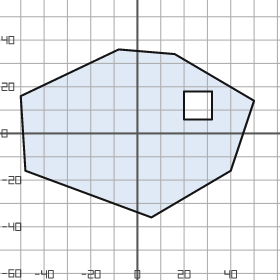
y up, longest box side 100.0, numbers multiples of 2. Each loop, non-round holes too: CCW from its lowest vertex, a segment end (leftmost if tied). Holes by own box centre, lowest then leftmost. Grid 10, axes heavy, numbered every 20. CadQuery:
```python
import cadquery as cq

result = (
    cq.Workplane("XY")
    .moveTo(6.0, -36.0)
    .lineTo(40.0, -16.0)
    .lineTo(50.0, 14.0)
    .lineTo(16.0, 34.0)
    .lineTo(-8.0, 36.0)
    .lineTo(-50.0, 16.0)
    .lineTo(-48.0, -16.0)
    .close()
    .moveTo(20.0, 6.0)
    .lineTo(32.0, 6.0)
    .lineTo(32.0, 18.0)
    .lineTo(20.0, 18.0)
    .close()
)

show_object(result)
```